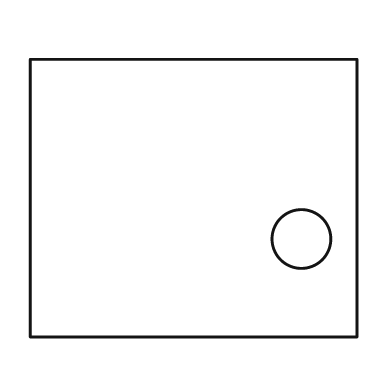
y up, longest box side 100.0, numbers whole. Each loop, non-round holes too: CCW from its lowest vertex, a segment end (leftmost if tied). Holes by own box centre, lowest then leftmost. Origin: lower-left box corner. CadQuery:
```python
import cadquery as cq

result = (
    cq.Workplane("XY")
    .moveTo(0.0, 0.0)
    .lineTo(100.0, 0.0)
    .lineTo(100.0, 85.0)
    .lineTo(0.0, 85.0)
    .close()
    .moveTo(83.0, 30.0)
    .circle(9.0)
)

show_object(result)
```